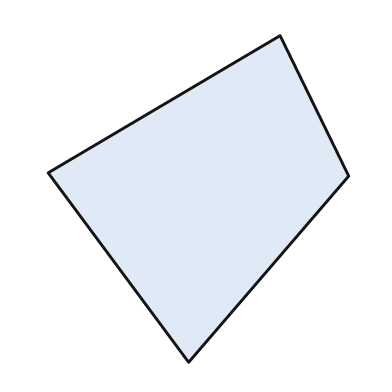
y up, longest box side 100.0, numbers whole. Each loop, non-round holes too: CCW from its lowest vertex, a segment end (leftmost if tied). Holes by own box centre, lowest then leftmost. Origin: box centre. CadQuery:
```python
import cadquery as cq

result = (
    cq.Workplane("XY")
    .moveTo(-3.0, -50.0)
    .lineTo(46.0, 7.0)
    .lineTo(25.0, 50.0)
    .lineTo(-46.0, 8.0)
    .close()
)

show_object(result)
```